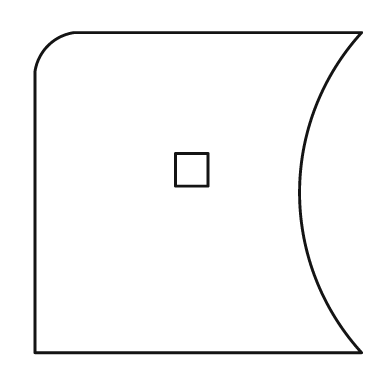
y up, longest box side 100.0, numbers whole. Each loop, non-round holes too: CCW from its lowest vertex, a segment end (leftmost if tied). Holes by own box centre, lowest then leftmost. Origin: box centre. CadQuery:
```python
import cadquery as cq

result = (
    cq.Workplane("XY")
    .moveTo(-50.0, -49.0)
    .lineTo(50.0, -49.0)
    .threePointArc((31.0, 0.0), (50.0, 49.0))
    .lineTo(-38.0, 49.0)
    .threePointArc((-46.0, 45.0), (-50.0, 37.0))
    .close()
    .moveTo(-7.0, 2.0)
    .lineTo(3.0, 2.0)
    .lineTo(3.0, 12.0)
    .lineTo(-7.0, 12.0)
    .close()
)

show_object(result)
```